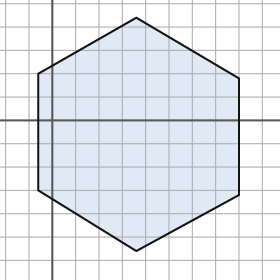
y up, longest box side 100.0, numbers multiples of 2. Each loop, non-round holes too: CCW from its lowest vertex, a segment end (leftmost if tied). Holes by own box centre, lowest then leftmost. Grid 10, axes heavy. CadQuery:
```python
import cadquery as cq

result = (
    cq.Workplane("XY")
    .moveTo(36.0, -56.0)
    .lineTo(80.0, -32.0)
    .lineTo(80.0, 18.0)
    .lineTo(36.0, 44.0)
    .lineTo(-6.0, 20.0)
    .lineTo(-6.0, -30.0)
    .close()
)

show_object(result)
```